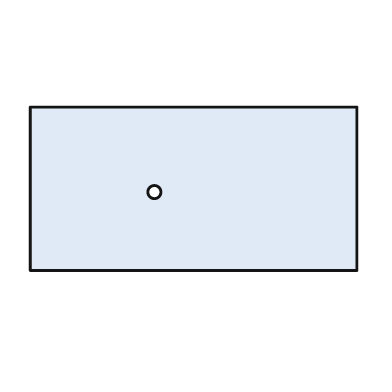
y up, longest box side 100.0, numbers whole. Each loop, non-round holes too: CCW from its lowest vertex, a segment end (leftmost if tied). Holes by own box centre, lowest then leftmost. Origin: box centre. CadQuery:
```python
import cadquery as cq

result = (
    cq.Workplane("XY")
    .moveTo(-50.0, -25.0)
    .lineTo(50.0, -25.0)
    .lineTo(50.0, 25.0)
    .lineTo(-50.0, 25.0)
    .close()
    .moveTo(-12.0, -1.0)
    .circle(2.0)
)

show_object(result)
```